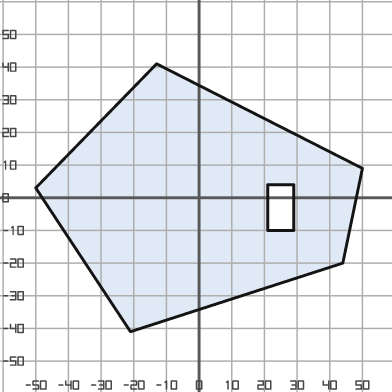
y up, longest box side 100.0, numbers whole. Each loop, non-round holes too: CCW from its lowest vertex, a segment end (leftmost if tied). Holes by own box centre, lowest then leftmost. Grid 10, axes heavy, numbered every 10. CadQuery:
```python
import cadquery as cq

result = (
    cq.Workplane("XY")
    .moveTo(-21.0, -41.0)
    .lineTo(44.0, -20.0)
    .lineTo(50.0, 9.0)
    .lineTo(-13.0, 41.0)
    .lineTo(-50.0, 3.0)
    .close()
    .moveTo(21.0, -10.0)
    .lineTo(29.0, -10.0)
    .lineTo(29.0, 4.0)
    .lineTo(21.0, 4.0)
    .close()
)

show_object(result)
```